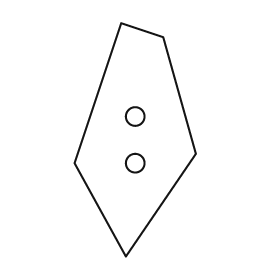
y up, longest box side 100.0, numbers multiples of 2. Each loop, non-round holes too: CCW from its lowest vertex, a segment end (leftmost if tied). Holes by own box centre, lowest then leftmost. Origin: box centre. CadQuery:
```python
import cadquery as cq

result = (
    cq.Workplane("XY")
    .moveTo(-4.0, -50.0)
    .lineTo(26.0, -6.0)
    .lineTo(12.0, 44.0)
    .lineTo(-6.0, 50.0)
    .lineTo(-26.0, -10.0)
    .close()
    .moveTo(0.0, -10.0)
    .circle(4.0)
    .moveTo(0.0, 10.0)
    .circle(4.0)
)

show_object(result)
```